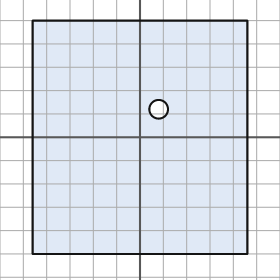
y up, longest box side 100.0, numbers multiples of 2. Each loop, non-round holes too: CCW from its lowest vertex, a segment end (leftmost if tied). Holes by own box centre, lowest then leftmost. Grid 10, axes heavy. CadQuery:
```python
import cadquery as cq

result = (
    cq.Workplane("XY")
    .moveTo(-46.0, -50.0)
    .lineTo(46.0, -50.0)
    .lineTo(46.0, 50.0)
    .lineTo(-46.0, 50.0)
    .close()
    .moveTo(8.0, 12.0)
    .circle(4.0)
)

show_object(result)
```